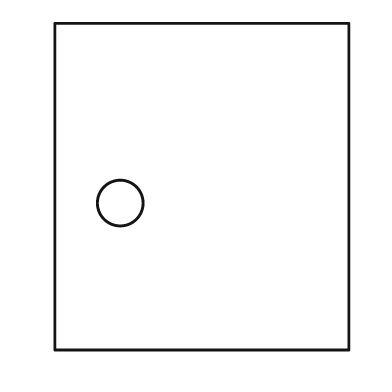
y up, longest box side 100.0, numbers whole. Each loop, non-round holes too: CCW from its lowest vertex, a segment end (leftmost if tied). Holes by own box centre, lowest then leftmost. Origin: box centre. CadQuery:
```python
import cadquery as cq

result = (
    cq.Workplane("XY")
    .moveTo(-45.0, -50.0)
    .lineTo(45.0, -50.0)
    .lineTo(45.0, 50.0)
    .lineTo(-45.0, 50.0)
    .close()
    .moveTo(-25.0, -5.0)
    .circle(7.0)
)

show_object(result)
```